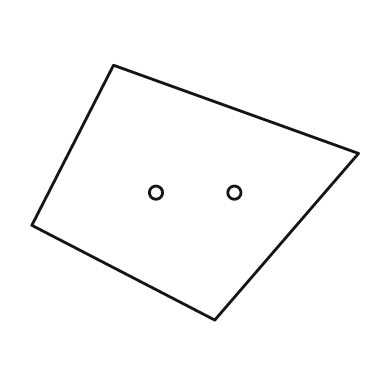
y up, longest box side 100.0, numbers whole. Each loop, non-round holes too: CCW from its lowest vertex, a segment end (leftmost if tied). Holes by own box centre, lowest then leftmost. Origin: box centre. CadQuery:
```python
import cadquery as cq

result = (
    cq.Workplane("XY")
    .moveTo(6.0, -39.0)
    .lineTo(50.0, 12.0)
    .lineTo(-25.0, 39.0)
    .lineTo(-50.0, -10.0)
    .close()
    .moveTo(-12.0, 0.0)
    .circle(2.0)
    .moveTo(12.0, 0.0)
    .circle(2.0)
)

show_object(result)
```